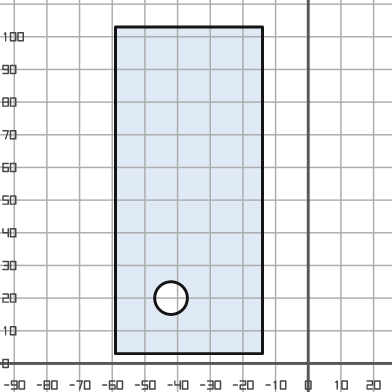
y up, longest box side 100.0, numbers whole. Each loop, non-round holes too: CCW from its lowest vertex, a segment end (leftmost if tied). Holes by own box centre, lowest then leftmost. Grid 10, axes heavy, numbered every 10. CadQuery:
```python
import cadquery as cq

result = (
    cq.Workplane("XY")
    .moveTo(-59.0, 3.0)
    .lineTo(-14.0, 3.0)
    .lineTo(-14.0, 103.0)
    .lineTo(-59.0, 103.0)
    .close()
    .moveTo(-42.0, 20.0)
    .circle(5.0)
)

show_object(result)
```